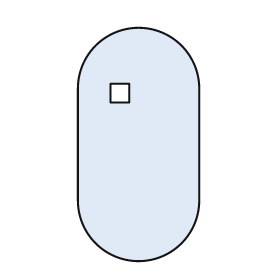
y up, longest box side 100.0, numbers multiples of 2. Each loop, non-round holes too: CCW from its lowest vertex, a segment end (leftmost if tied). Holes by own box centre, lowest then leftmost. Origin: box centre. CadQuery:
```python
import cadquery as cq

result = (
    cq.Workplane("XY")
    .moveTo(-26.0, -24.0)
    .threePointArc((0.0, -50.0), (26.0, -24.0))
    .lineTo(26.0, 24.0)
    .threePointArc((0.0, 50.0), (-26.0, 24.0))
    .close()
    .moveTo(-12.0, 18.0)
    .lineTo(-4.0, 18.0)
    .lineTo(-4.0, 26.0)
    .lineTo(-12.0, 26.0)
    .close()
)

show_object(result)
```